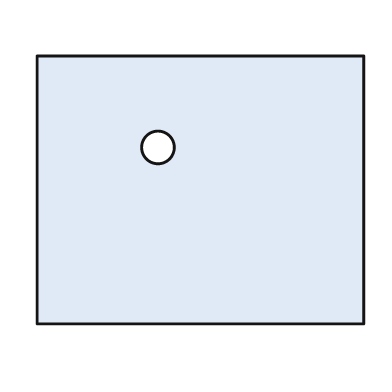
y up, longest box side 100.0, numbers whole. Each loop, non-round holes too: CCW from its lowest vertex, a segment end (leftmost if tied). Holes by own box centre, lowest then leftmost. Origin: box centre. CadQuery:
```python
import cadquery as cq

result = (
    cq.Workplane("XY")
    .moveTo(-50.0, -41.0)
    .lineTo(50.0, -41.0)
    .lineTo(50.0, 41.0)
    .lineTo(-50.0, 41.0)
    .close()
    .moveTo(-13.0, 13.0)
    .circle(5.0)
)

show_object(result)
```